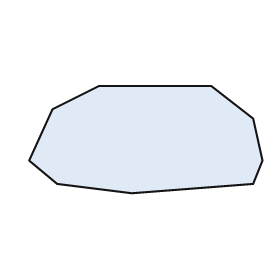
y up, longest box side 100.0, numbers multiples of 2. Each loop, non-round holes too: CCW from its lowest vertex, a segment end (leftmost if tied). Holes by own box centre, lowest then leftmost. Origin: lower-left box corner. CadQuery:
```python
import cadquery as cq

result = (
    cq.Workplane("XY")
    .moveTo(44.0, 0.0)
    .lineTo(96.0, 4.0)
    .lineTo(100.0, 14.0)
    .lineTo(96.0, 32.0)
    .lineTo(78.0, 46.0)
    .lineTo(30.0, 46.0)
    .lineTo(10.0, 36.0)
    .lineTo(0.0, 14.0)
    .lineTo(12.0, 4.0)
    .close()
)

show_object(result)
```